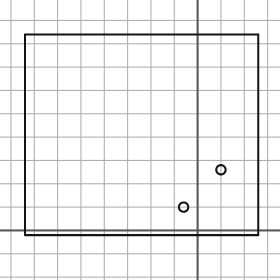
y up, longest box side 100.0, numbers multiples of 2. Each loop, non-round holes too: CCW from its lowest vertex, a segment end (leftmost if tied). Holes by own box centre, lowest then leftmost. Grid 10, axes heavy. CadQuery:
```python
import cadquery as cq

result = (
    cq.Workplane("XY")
    .moveTo(-74.0, -2.0)
    .lineTo(26.0, -2.0)
    .lineTo(26.0, 84.0)
    .lineTo(-74.0, 84.0)
    .close()
    .moveTo(-6.0, 10.0)
    .circle(2.0)
    .moveTo(10.0, 26.0)
    .circle(2.0)
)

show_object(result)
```